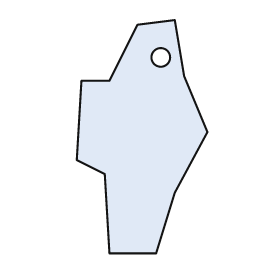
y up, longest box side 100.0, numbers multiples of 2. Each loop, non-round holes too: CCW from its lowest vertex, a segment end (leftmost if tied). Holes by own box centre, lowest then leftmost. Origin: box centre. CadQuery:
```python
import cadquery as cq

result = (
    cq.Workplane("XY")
    .moveTo(-14.0, -50.0)
    .lineTo(6.0, -50.0)
    .lineTo(14.0, -24.0)
    .lineTo(28.0, 2.0)
    .lineTo(18.0, 26.0)
    .lineTo(14.0, 50.0)
    .lineTo(-2.0, 48.0)
    .lineTo(-14.0, 24.0)
    .lineTo(-26.0, 24.0)
    .lineTo(-28.0, -10.0)
    .lineTo(-16.0, -16.0)
    .close()
    .moveTo(8.0, 34.0)
    .circle(4.0)
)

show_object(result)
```